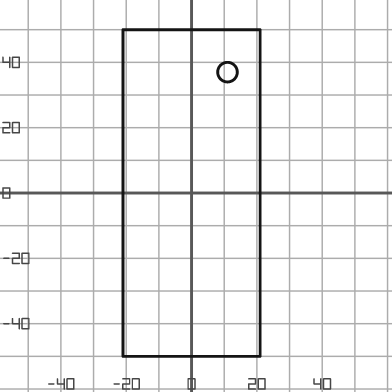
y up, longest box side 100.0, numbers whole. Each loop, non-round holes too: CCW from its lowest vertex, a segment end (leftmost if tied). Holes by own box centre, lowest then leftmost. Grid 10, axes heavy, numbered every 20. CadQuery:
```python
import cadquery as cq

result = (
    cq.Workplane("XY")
    .moveTo(-21.0, -50.0)
    .lineTo(21.0, -50.0)
    .lineTo(21.0, 50.0)
    .lineTo(-21.0, 50.0)
    .close()
    .moveTo(11.0, 37.0)
    .circle(3.0)
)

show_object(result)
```